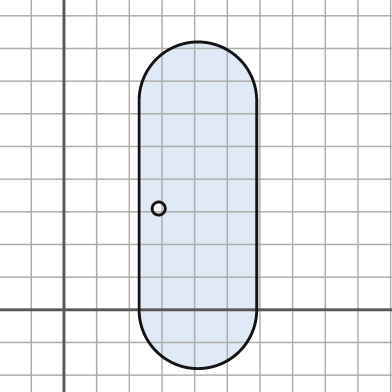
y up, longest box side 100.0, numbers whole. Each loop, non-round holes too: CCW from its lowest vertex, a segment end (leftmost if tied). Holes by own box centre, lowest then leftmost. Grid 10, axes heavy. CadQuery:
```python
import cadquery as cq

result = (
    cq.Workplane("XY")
    .moveTo(23.0, 0.0)
    .threePointArc((41.0, -18.0), (59.0, 0.0))
    .lineTo(59.0, 64.0)
    .threePointArc((41.0, 82.0), (23.0, 64.0))
    .close()
    .moveTo(29.0, 31.0)
    .circle(2.0)
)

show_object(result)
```